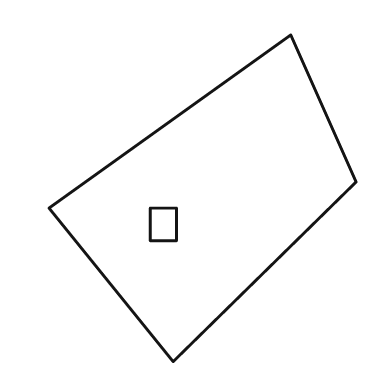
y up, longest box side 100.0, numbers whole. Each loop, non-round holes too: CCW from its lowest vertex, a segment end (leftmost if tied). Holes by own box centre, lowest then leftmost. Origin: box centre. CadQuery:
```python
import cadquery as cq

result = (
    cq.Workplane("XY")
    .moveTo(-9.0, -50.0)
    .lineTo(47.0, 5.0)
    .lineTo(27.0, 50.0)
    .lineTo(-47.0, -3.0)
    .close()
    .moveTo(-16.0, -13.0)
    .lineTo(-8.0, -13.0)
    .lineTo(-8.0, -3.0)
    .lineTo(-16.0, -3.0)
    .close()
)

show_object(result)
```